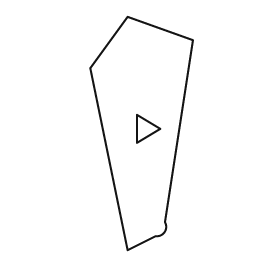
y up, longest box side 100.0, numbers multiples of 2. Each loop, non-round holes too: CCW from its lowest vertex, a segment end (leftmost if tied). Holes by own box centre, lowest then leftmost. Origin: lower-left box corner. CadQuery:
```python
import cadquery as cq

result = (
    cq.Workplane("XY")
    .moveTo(16.0, 0.0)
    .lineTo(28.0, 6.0)
    .threePointArc((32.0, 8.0), (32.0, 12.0))
    .lineTo(44.0, 90.0)
    .lineTo(16.0, 100.0)
    .lineTo(0.0, 78.0)
    .close()
    .moveTo(20.0, 46.0)
    .lineTo(30.0, 52.0)
    .lineTo(20.0, 58.0)
    .close()
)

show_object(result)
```